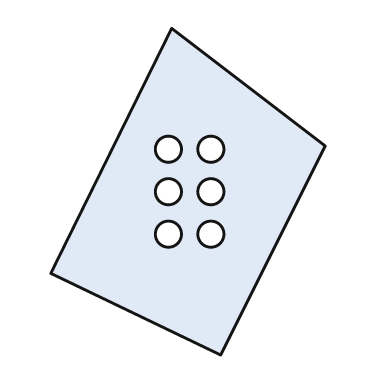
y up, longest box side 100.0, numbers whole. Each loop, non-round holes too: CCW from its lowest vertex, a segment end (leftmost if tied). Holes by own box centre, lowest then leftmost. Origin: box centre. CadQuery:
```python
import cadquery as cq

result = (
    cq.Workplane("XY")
    .moveTo(10.0, -50.0)
    .lineTo(42.0, 14.0)
    .lineTo(-5.0, 50.0)
    .lineTo(-42.0, -25.0)
    .close()
    .moveTo(-6.0, -13.0)
    .circle(4.0)
    .moveTo(7.0, -13.0)
    .circle(4.0)
    .moveTo(-6.0, 0.0)
    .circle(4.0)
    .moveTo(7.0, 0.0)
    .circle(4.0)
    .moveTo(-6.0, 13.0)
    .circle(4.0)
    .moveTo(7.0, 13.0)
    .circle(4.0)
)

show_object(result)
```